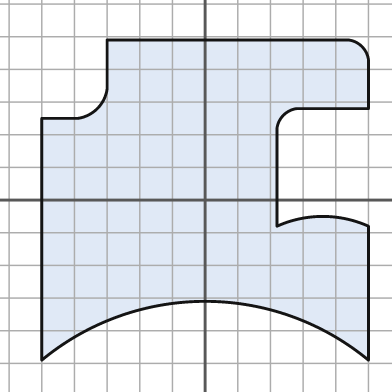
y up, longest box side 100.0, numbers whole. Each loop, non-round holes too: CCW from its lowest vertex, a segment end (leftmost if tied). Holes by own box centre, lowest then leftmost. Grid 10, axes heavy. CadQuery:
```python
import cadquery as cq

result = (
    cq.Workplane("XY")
    .moveTo(-50.0, -49.0)
    .threePointArc((0.0, -31.0), (50.0, -49.0))
    .lineTo(50.0, -8.0)
    .threePointArc((36.0, -5.0), (22.0, -8.0))
    .lineTo(22.0, 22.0)
    .threePointArc((24.0, 26.0), (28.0, 28.0))
    .lineTo(50.0, 28.0)
    .lineTo(50.0, 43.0)
    .threePointArc((48.0, 47.0), (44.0, 49.0))
    .lineTo(-30.0, 49.0)
    .lineTo(-30.0, 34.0)
    .threePointArc((-33.0, 28.0), (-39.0, 25.0))
    .lineTo(-50.0, 25.0)
    .close()
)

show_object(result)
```